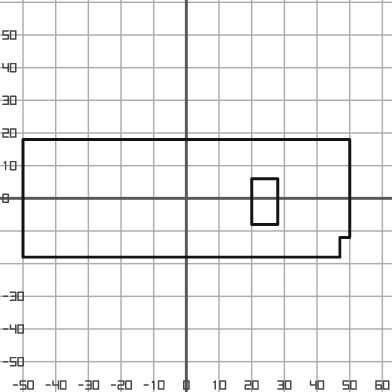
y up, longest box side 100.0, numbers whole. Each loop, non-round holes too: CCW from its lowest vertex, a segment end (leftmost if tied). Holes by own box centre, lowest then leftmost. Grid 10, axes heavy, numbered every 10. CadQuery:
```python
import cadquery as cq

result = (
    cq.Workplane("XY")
    .moveTo(-50.0, -18.0)
    .lineTo(47.0, -18.0)
    .lineTo(47.0, -12.0)
    .lineTo(50.0, -12.0)
    .lineTo(50.0, 18.0)
    .lineTo(-50.0, 18.0)
    .close()
    .moveTo(20.0, -8.0)
    .lineTo(28.0, -8.0)
    .lineTo(28.0, 6.0)
    .lineTo(20.0, 6.0)
    .close()
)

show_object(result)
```